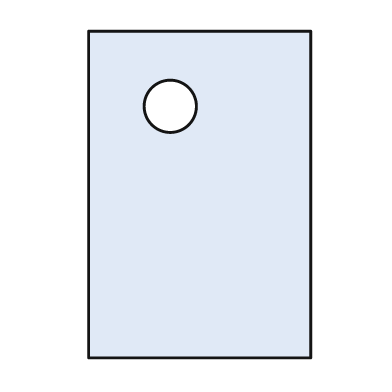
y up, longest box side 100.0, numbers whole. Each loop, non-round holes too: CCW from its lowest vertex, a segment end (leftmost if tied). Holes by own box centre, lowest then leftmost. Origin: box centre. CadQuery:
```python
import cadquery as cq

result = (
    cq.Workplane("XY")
    .moveTo(-34.0, -50.0)
    .lineTo(34.0, -50.0)
    .lineTo(34.0, 50.0)
    .lineTo(-34.0, 50.0)
    .close()
    .moveTo(-9.0, 27.0)
    .circle(8.0)
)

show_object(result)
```